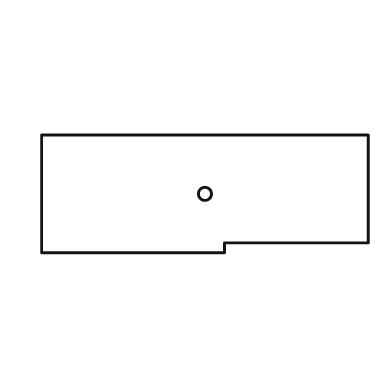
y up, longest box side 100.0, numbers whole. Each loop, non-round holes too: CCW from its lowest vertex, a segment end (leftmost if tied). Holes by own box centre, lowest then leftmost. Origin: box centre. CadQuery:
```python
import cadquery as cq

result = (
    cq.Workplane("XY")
    .moveTo(-50.0, -18.0)
    .lineTo(6.0, -18.0)
    .lineTo(6.0, -15.0)
    .lineTo(50.0, -15.0)
    .lineTo(50.0, 18.0)
    .lineTo(-50.0, 18.0)
    .close()
    .moveTo(0.0, 0.0)
    .circle(2.0)
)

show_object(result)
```